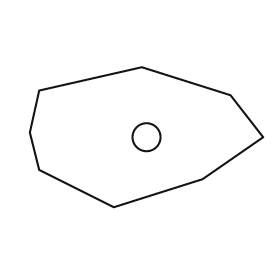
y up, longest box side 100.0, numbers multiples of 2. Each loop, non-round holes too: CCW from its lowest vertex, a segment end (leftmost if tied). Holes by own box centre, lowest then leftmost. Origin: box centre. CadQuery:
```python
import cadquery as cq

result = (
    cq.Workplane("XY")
    .moveTo(-14.0, -30.0)
    .lineTo(24.0, -18.0)
    .lineTo(50.0, 0.0)
    .lineTo(36.0, 18.0)
    .lineTo(-2.0, 30.0)
    .lineTo(-46.0, 20.0)
    .lineTo(-50.0, 2.0)
    .lineTo(-46.0, -14.0)
    .close()
    .moveTo(0.0, 0.0)
    .circle(6.0)
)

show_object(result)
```